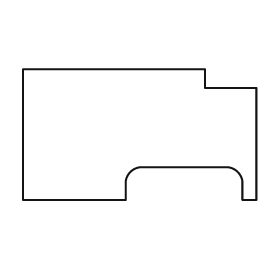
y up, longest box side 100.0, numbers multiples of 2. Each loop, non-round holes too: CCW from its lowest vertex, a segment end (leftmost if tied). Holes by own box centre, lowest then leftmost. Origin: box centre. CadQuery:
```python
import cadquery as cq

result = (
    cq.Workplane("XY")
    .moveTo(-50.0, -28.0)
    .lineTo(-6.0, -28.0)
    .lineTo(-6.0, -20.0)
    .threePointArc((-4.0, -16.0), (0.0, -14.0))
    .lineTo(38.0, -14.0)
    .threePointArc((42.0, -16.0), (44.0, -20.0))
    .lineTo(44.0, -28.0)
    .lineTo(50.0, -28.0)
    .lineTo(50.0, 20.0)
    .lineTo(28.0, 20.0)
    .lineTo(28.0, 28.0)
    .lineTo(-50.0, 28.0)
    .close()
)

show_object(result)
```